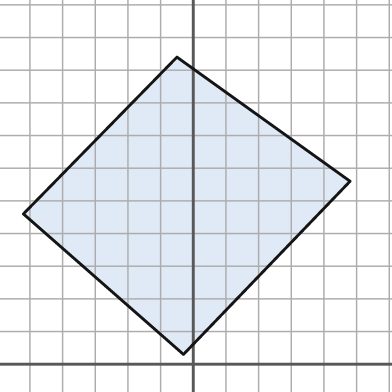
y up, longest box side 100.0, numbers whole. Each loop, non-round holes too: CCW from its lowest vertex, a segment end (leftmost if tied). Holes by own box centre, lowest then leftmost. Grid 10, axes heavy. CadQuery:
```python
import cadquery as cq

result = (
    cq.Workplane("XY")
    .moveTo(-3.0, 3.0)
    .lineTo(48.0, 56.0)
    .lineTo(-5.0, 94.0)
    .lineTo(-52.0, 46.0)
    .close()
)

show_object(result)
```